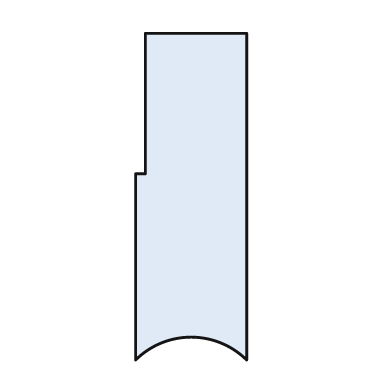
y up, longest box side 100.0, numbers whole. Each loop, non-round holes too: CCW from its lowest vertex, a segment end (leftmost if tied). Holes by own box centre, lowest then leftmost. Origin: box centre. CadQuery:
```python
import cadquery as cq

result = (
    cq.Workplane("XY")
    .moveTo(-17.0, -50.0)
    .threePointArc((0.0, -43.0), (17.0, -50.0))
    .lineTo(17.0, 50.0)
    .lineTo(-14.0, 50.0)
    .lineTo(-14.0, 7.0)
    .lineTo(-17.0, 7.0)
    .close()
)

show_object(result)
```